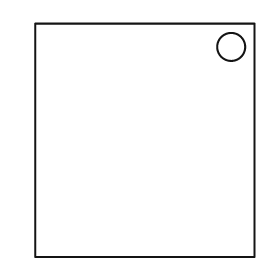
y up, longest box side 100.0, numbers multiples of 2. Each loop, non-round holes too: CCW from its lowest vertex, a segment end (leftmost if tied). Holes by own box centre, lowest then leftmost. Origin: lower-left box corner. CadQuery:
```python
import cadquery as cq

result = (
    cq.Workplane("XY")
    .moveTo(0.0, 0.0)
    .lineTo(94.0, 0.0)
    .lineTo(94.0, 100.0)
    .lineTo(0.0, 100.0)
    .close()
    .moveTo(84.0, 90.0)
    .circle(6.0)
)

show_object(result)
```